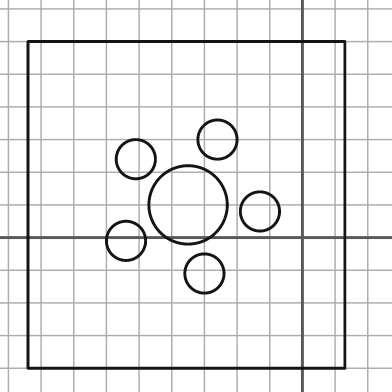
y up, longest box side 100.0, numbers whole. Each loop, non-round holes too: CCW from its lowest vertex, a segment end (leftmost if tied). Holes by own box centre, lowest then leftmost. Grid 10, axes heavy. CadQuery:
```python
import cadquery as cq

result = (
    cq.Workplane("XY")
    .moveTo(-84.0, -40.0)
    .lineTo(13.0, -40.0)
    .lineTo(13.0, 60.0)
    .lineTo(-84.0, 60.0)
    .close()
    .moveTo(-30.0, -11.0)
    .circle(6.0)
    .moveTo(-54.0, -1.0)
    .circle(6.0)
    .moveTo(-13.0, 8.0)
    .circle(6.0)
    .moveTo(-35.0, 10.0)
    .circle(12.0)
    .moveTo(-51.0, 24.0)
    .circle(6.0)
    .moveTo(-26.0, 30.0)
    .circle(6.0)
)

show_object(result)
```